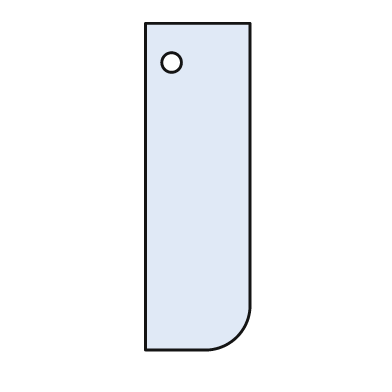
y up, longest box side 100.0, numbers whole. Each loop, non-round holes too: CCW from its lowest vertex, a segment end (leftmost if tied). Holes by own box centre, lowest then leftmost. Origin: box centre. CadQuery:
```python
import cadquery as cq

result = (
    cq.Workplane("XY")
    .moveTo(-16.0, -50.0)
    .lineTo(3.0, -50.0)
    .threePointArc((12.0, -46.0), (16.0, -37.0))
    .lineTo(16.0, 50.0)
    .lineTo(-16.0, 50.0)
    .close()
    .moveTo(-8.0, 38.0)
    .circle(3.0)
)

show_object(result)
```